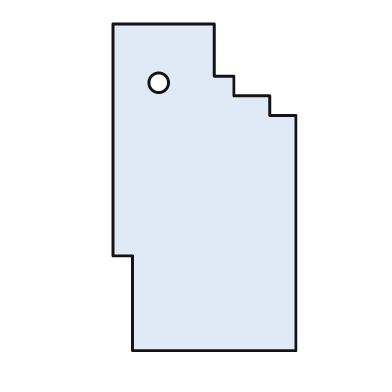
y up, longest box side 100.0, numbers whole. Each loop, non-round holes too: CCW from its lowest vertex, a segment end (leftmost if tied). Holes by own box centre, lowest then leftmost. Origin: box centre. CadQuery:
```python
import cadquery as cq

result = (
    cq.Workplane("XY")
    .moveTo(-22.0, -50.0)
    .lineTo(28.0, -50.0)
    .lineTo(28.0, 22.0)
    .lineTo(20.0, 22.0)
    .lineTo(20.0, 28.0)
    .lineTo(9.0, 28.0)
    .lineTo(9.0, 34.0)
    .lineTo(3.0, 34.0)
    .lineTo(3.0, 50.0)
    .lineTo(-28.0, 50.0)
    .lineTo(-28.0, -21.0)
    .lineTo(-22.0, -21.0)
    .close()
    .moveTo(-14.0, 32.0)
    .circle(3.0)
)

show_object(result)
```